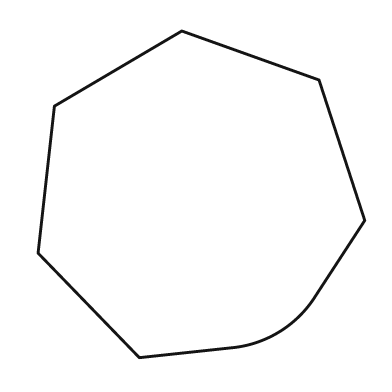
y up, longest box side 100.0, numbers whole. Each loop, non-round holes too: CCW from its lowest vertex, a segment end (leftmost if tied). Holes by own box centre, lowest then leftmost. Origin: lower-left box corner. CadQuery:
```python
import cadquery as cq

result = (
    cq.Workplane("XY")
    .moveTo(31.0, 0.0)
    .lineTo(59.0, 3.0)
    .threePointArc((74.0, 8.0), (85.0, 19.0))
    .lineTo(100.0, 42.0)
    .lineTo(86.0, 85.0)
    .lineTo(44.0, 100.0)
    .lineTo(5.0, 77.0)
    .lineTo(0.0, 32.0)
    .close()
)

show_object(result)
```